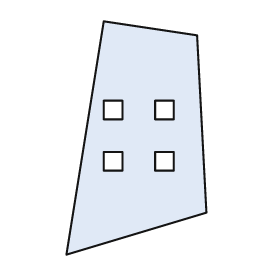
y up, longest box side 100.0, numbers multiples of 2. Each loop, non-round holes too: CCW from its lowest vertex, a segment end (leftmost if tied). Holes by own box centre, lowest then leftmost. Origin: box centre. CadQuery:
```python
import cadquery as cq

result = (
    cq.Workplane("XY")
    .moveTo(-30.0, -50.0)
    .lineTo(30.0, -32.0)
    .lineTo(26.0, 44.0)
    .lineTo(-14.0, 50.0)
    .close()
    .moveTo(-14.0, -14.0)
    .lineTo(-6.0, -14.0)
    .lineTo(-6.0, -6.0)
    .lineTo(-14.0, -6.0)
    .close()
    .moveTo(8.0, -14.0)
    .lineTo(16.0, -14.0)
    .lineTo(16.0, -6.0)
    .lineTo(8.0, -6.0)
    .close()
    .moveTo(-14.0, 8.0)
    .lineTo(-6.0, 8.0)
    .lineTo(-6.0, 16.0)
    .lineTo(-14.0, 16.0)
    .close()
    .moveTo(8.0, 8.0)
    .lineTo(16.0, 8.0)
    .lineTo(16.0, 16.0)
    .lineTo(8.0, 16.0)
    .close()
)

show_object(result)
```